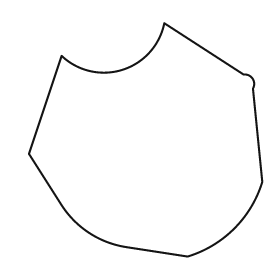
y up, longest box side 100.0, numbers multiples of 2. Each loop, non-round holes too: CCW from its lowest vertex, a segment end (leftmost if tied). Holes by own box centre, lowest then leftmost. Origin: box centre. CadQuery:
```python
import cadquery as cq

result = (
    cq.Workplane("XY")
    .moveTo(18.0, -50.0)
    .threePointArc((38.0, -38.0), (50.0, -18.0))
    .lineTo(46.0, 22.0)
    .threePointArc((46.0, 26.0), (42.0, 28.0))
    .lineTo(8.0, 50.0)
    .threePointArc((-10.0, 30.0), (-36.0, 36.0))
    .lineTo(-50.0, -6.0)
    .lineTo(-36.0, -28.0)
    .threePointArc((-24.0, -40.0), (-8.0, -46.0))
    .close()
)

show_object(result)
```